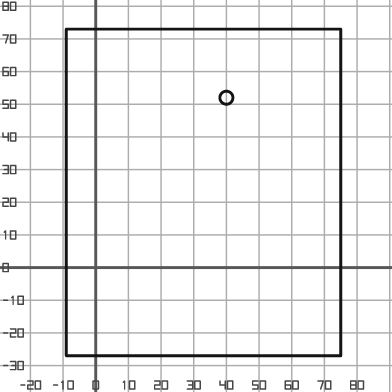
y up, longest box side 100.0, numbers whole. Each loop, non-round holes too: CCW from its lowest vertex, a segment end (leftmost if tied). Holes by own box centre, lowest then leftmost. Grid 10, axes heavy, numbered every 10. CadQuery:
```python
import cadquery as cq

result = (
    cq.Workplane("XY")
    .moveTo(-9.0, -27.0)
    .lineTo(75.0, -27.0)
    .lineTo(75.0, 73.0)
    .lineTo(-9.0, 73.0)
    .close()
    .moveTo(40.0, 52.0)
    .circle(2.0)
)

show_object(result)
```